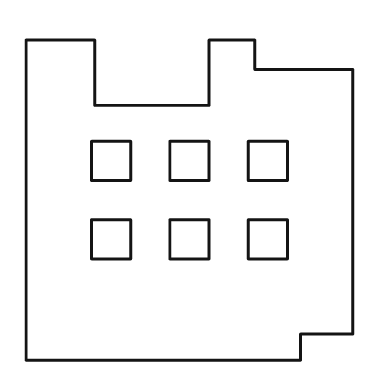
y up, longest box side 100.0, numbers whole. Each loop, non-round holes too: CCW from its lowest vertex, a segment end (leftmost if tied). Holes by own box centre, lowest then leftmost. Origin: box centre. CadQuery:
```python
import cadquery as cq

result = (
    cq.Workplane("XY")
    .moveTo(-50.0, -49.0)
    .lineTo(34.0, -49.0)
    .lineTo(34.0, -41.0)
    .lineTo(50.0, -41.0)
    .lineTo(50.0, 40.0)
    .lineTo(20.0, 40.0)
    .lineTo(20.0, 49.0)
    .lineTo(6.0, 49.0)
    .lineTo(6.0, 29.0)
    .lineTo(-29.0, 29.0)
    .lineTo(-29.0, 49.0)
    .lineTo(-50.0, 49.0)
    .close()
    .moveTo(-30.0, -18.0)
    .lineTo(-18.0, -18.0)
    .lineTo(-18.0, -6.0)
    .lineTo(-30.0, -6.0)
    .close()
    .moveTo(-6.0, -18.0)
    .lineTo(6.0, -18.0)
    .lineTo(6.0, -6.0)
    .lineTo(-6.0, -6.0)
    .close()
    .moveTo(18.0, -18.0)
    .lineTo(30.0, -18.0)
    .lineTo(30.0, -6.0)
    .lineTo(18.0, -6.0)
    .close()
    .moveTo(-30.0, 6.0)
    .lineTo(-18.0, 6.0)
    .lineTo(-18.0, 18.0)
    .lineTo(-30.0, 18.0)
    .close()
    .moveTo(-6.0, 6.0)
    .lineTo(6.0, 6.0)
    .lineTo(6.0, 18.0)
    .lineTo(-6.0, 18.0)
    .close()
    .moveTo(18.0, 6.0)
    .lineTo(30.0, 6.0)
    .lineTo(30.0, 18.0)
    .lineTo(18.0, 18.0)
    .close()
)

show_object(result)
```